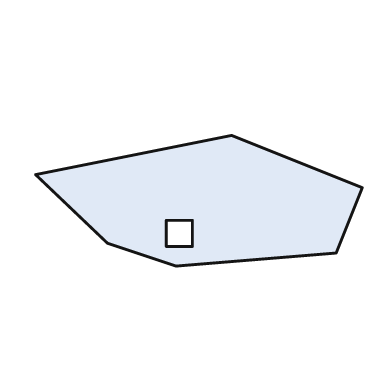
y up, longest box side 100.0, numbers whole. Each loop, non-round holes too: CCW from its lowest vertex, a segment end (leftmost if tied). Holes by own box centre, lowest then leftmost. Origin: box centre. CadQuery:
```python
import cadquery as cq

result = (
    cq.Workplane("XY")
    .moveTo(-7.0, -20.0)
    .lineTo(42.0, -16.0)
    .lineTo(50.0, 4.0)
    .lineTo(10.0, 20.0)
    .lineTo(-50.0, 8.0)
    .lineTo(-28.0, -13.0)
    .close()
    .moveTo(-10.0, -14.0)
    .lineTo(-2.0, -14.0)
    .lineTo(-2.0, -6.0)
    .lineTo(-10.0, -6.0)
    .close()
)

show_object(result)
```